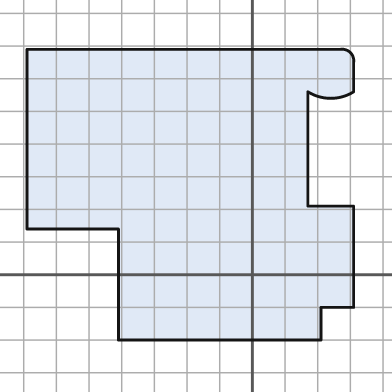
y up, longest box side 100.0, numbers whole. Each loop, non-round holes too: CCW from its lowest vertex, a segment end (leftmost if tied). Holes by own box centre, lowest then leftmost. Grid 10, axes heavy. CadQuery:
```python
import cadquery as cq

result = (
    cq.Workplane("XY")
    .moveTo(-41.0, -20.0)
    .lineTo(21.0, -20.0)
    .lineTo(21.0, -10.0)
    .lineTo(31.0, -10.0)
    .lineTo(31.0, 21.0)
    .lineTo(17.0, 21.0)
    .lineTo(17.0, 56.0)
    .threePointArc((24.0, 54.0), (31.0, 56.0))
    .lineTo(31.0, 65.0)
    .threePointArc((30.0, 68.0), (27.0, 69.0))
    .lineTo(-69.0, 69.0)
    .lineTo(-69.0, 14.0)
    .lineTo(-41.0, 14.0)
    .close()
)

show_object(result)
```